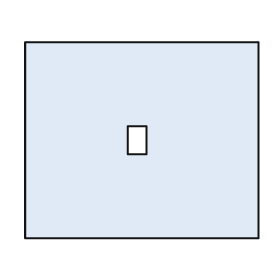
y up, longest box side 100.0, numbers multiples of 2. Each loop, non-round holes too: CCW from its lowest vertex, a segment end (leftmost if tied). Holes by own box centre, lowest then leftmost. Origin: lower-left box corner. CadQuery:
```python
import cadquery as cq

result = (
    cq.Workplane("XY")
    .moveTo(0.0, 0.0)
    .lineTo(100.0, 0.0)
    .lineTo(100.0, 84.0)
    .lineTo(0.0, 84.0)
    .close()
    .moveTo(44.0, 36.0)
    .lineTo(52.0, 36.0)
    .lineTo(52.0, 48.0)
    .lineTo(44.0, 48.0)
    .close()
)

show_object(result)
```